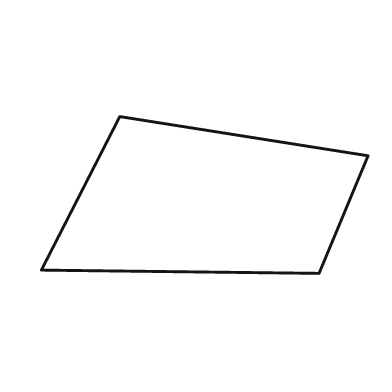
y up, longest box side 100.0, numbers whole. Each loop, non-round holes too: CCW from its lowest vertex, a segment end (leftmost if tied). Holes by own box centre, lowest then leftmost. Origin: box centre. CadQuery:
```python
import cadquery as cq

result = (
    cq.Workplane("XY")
    .moveTo(35.0, -24.0)
    .lineTo(50.0, 12.0)
    .lineTo(-26.0, 24.0)
    .lineTo(-50.0, -23.0)
    .close()
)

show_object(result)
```